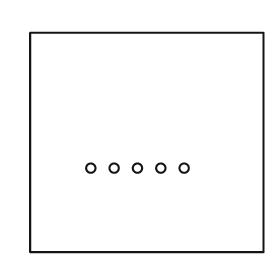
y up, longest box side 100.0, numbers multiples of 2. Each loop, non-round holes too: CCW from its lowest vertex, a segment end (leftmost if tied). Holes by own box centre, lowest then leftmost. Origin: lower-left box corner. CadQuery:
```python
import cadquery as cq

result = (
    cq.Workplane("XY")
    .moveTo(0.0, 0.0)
    .lineTo(100.0, 0.0)
    .lineTo(100.0, 94.0)
    .lineTo(0.0, 94.0)
    .close()
    .moveTo(26.0, 36.0)
    .circle(2.0)
    .moveTo(36.0, 36.0)
    .circle(2.0)
    .moveTo(46.0, 36.0)
    .circle(2.0)
    .moveTo(56.0, 36.0)
    .circle(2.0)
    .moveTo(66.0, 36.0)
    .circle(2.0)
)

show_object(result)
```